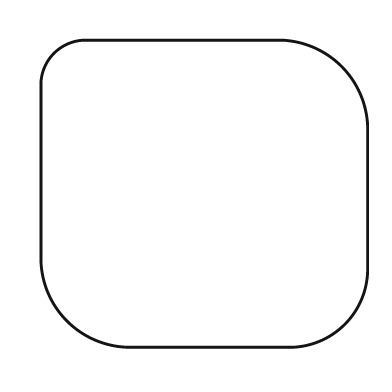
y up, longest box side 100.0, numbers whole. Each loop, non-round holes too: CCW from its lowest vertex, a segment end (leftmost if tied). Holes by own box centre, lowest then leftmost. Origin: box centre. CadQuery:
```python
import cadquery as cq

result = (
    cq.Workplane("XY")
    .moveTo(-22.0, -47.0)
    .lineTo(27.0, -47.0)
    .threePointArc((43.0, -40.0), (50.0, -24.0))
    .lineTo(50.0, 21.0)
    .threePointArc((42.0, 39.0), (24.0, 47.0))
    .lineTo(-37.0, 47.0)
    .threePointArc((-46.0, 43.0), (-50.0, 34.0))
    .lineTo(-50.0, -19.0)
    .threePointArc((-42.0, -39.0), (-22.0, -47.0))
    .close()
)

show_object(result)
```